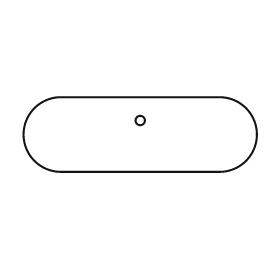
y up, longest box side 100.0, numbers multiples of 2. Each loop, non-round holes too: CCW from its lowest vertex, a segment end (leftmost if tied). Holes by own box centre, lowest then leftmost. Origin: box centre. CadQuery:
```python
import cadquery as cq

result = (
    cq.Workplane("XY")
    .moveTo(-34.0, -16.0)
    .lineTo(34.0, -16.0)
    .threePointArc((50.0, 0.0), (34.0, 16.0))
    .lineTo(-34.0, 16.0)
    .threePointArc((-50.0, 0.0), (-34.0, -16.0))
    .close()
    .moveTo(0.0, 6.0)
    .circle(2.0)
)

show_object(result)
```